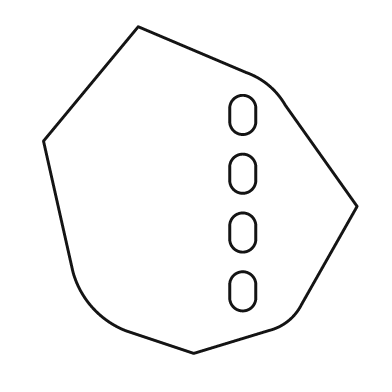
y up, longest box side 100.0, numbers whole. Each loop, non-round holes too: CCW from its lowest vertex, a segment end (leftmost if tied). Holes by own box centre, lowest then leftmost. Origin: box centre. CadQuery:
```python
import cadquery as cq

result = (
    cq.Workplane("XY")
    .moveTo(-2.0, -50.0)
    .lineTo(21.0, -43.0)
    .threePointArc((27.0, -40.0), (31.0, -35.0))
    .lineTo(48.0, -5.0)
    .lineTo(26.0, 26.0)
    .threePointArc((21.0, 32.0), (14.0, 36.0))
    .lineTo(-19.0, 50.0)
    .lineTo(-48.0, 15.0)
    .lineTo(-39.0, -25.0)
    .threePointArc((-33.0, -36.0), (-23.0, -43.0))
    .close()
    .moveTo(9.0, -33.0)
    .threePointArc((13.0, -37.0), (17.0, -33.0))
    .lineTo(17.0, -29.0)
    .threePointArc((13.0, -25.0), (9.0, -29.0))
    .close()
    .moveTo(9.0, -15.0)
    .threePointArc((13.0, -19.0), (17.0, -15.0))
    .lineTo(17.0, -11.0)
    .threePointArc((13.0, -7.0), (9.0, -11.0))
    .close()
    .moveTo(9.0, 3.0)
    .threePointArc((13.0, -1.0), (17.0, 3.0))
    .lineTo(17.0, 7.0)
    .threePointArc((13.0, 11.0), (9.0, 7.0))
    .close()
    .moveTo(9.0, 21.0)
    .threePointArc((13.0, 17.0), (17.0, 21.0))
    .lineTo(17.0, 25.0)
    .threePointArc((13.0, 29.0), (9.0, 25.0))
    .close()
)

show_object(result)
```